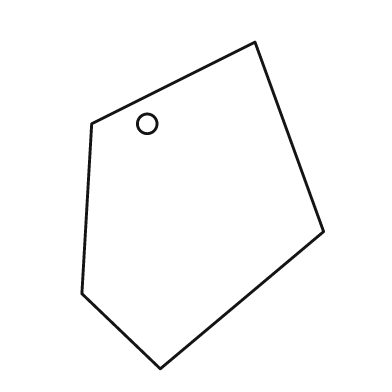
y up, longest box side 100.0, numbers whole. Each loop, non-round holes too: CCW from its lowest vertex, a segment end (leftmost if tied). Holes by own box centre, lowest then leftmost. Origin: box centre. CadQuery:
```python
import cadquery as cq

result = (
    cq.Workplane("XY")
    .moveTo(-13.0, -50.0)
    .lineTo(37.0, -8.0)
    .lineTo(16.0, 50.0)
    .lineTo(-34.0, 25.0)
    .lineTo(-37.0, -27.0)
    .close()
    .moveTo(-17.0, 25.0)
    .circle(3.0)
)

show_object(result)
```